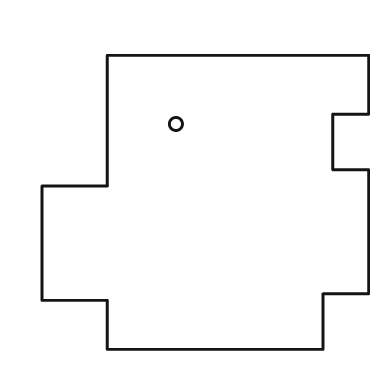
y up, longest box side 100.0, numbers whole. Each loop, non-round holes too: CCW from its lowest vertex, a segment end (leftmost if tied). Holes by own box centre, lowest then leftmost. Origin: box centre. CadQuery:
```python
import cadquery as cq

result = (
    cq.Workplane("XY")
    .moveTo(-30.0, -45.0)
    .lineTo(36.0, -45.0)
    .lineTo(36.0, -28.0)
    .lineTo(50.0, -28.0)
    .lineTo(50.0, 10.0)
    .lineTo(39.0, 10.0)
    .lineTo(39.0, 27.0)
    .lineTo(50.0, 27.0)
    .lineTo(50.0, 45.0)
    .lineTo(-30.0, 45.0)
    .lineTo(-30.0, 5.0)
    .lineTo(-50.0, 5.0)
    .lineTo(-50.0, -30.0)
    .lineTo(-30.0, -30.0)
    .close()
    .moveTo(-9.0, 24.0)
    .circle(2.0)
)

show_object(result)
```